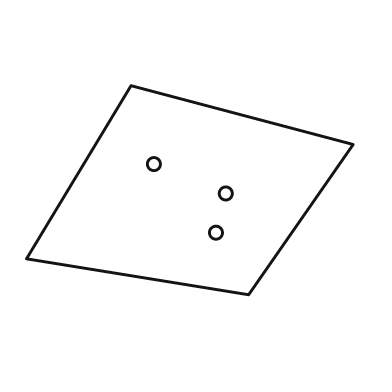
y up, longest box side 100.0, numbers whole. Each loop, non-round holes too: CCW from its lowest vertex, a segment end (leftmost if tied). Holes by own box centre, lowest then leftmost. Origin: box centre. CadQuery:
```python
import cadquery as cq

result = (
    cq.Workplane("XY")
    .moveTo(18.0, -32.0)
    .lineTo(50.0, 14.0)
    .lineTo(-18.0, 32.0)
    .lineTo(-50.0, -21.0)
    .close()
    .moveTo(8.0, -13.0)
    .circle(2.0)
    .moveTo(11.0, -1.0)
    .circle(2.0)
    .moveTo(-11.0, 8.0)
    .circle(2.0)
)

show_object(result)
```